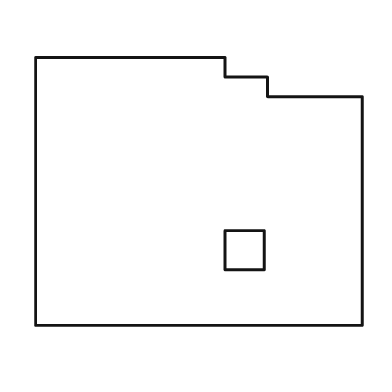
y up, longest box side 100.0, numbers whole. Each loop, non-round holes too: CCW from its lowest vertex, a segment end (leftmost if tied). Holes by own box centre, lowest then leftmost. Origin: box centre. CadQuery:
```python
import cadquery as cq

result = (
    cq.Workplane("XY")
    .moveTo(-50.0, -41.0)
    .lineTo(50.0, -41.0)
    .lineTo(50.0, 29.0)
    .lineTo(21.0, 29.0)
    .lineTo(21.0, 35.0)
    .lineTo(8.0, 35.0)
    .lineTo(8.0, 41.0)
    .lineTo(-50.0, 41.0)
    .close()
    .moveTo(8.0, -24.0)
    .lineTo(20.0, -24.0)
    .lineTo(20.0, -12.0)
    .lineTo(8.0, -12.0)
    .close()
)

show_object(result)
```